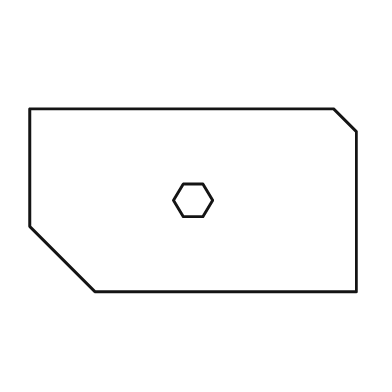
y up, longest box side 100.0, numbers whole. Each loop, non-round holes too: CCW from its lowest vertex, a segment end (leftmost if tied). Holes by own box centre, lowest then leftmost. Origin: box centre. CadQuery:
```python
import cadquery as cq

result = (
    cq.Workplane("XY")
    .moveTo(-30.0, -28.0)
    .lineTo(50.0, -28.0)
    .lineTo(50.0, 21.0)
    .lineTo(43.0, 28.0)
    .lineTo(-50.0, 28.0)
    .lineTo(-50.0, -8.0)
    .close()
    .moveTo(-3.0, -5.0)
    .lineTo(3.0, -5.0)
    .lineTo(6.0, 0.0)
    .lineTo(3.0, 5.0)
    .lineTo(-3.0, 5.0)
    .lineTo(-6.0, 0.0)
    .close()
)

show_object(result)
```